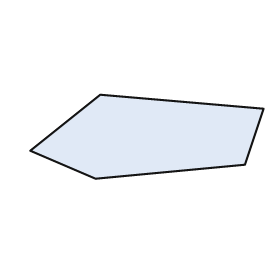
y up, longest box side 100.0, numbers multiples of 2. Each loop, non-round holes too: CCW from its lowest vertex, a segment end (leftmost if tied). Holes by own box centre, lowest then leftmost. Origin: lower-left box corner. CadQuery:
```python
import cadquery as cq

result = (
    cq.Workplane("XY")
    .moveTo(28.0, 0.0)
    .lineTo(92.0, 6.0)
    .lineTo(100.0, 30.0)
    .lineTo(30.0, 36.0)
    .lineTo(0.0, 12.0)
    .close()
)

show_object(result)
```